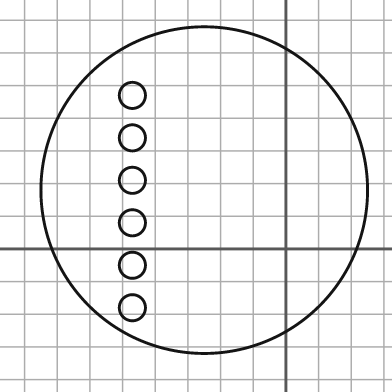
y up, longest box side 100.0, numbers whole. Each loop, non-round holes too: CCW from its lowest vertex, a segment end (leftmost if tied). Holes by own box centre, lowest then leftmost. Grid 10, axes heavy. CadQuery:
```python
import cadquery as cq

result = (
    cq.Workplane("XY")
    .moveTo(-25.0, 18.0)
    .circle(50.0)
    .moveTo(-47.0, -18.0)
    .circle(4.0)
    .moveTo(-47.0, -5.0)
    .circle(4.0)
    .moveTo(-47.0, 8.0)
    .circle(4.0)
    .moveTo(-47.0, 21.0)
    .circle(4.0)
    .moveTo(-47.0, 34.0)
    .circle(4.0)
    .moveTo(-47.0, 47.0)
    .circle(4.0)
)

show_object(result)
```